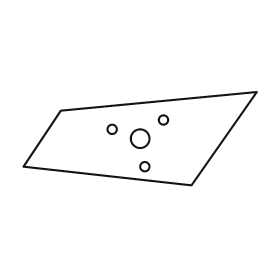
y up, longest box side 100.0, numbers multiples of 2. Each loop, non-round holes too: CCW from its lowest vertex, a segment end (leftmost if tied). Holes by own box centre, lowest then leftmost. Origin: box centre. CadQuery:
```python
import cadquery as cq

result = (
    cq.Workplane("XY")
    .moveTo(22.0, -20.0)
    .lineTo(50.0, 20.0)
    .lineTo(-34.0, 12.0)
    .lineTo(-50.0, -12.0)
    .close()
    .moveTo(2.0, -12.0)
    .circle(2.0)
    .moveTo(0.0, 0.0)
    .circle(4.0)
    .moveTo(-12.0, 4.0)
    .circle(2.0)
    .moveTo(10.0, 8.0)
    .circle(2.0)
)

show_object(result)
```